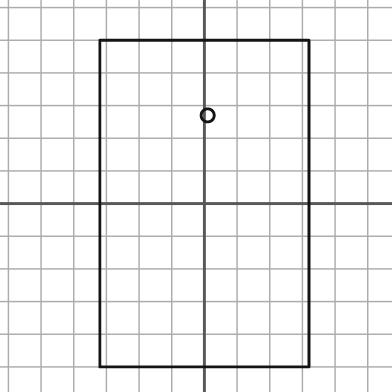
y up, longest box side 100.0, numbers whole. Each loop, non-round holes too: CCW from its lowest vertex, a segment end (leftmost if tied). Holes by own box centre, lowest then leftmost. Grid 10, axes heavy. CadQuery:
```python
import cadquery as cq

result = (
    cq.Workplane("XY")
    .moveTo(-32.0, -50.0)
    .lineTo(32.0, -50.0)
    .lineTo(32.0, 50.0)
    .lineTo(-32.0, 50.0)
    .close()
    .moveTo(1.0, 27.0)
    .circle(2.0)
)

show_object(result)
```